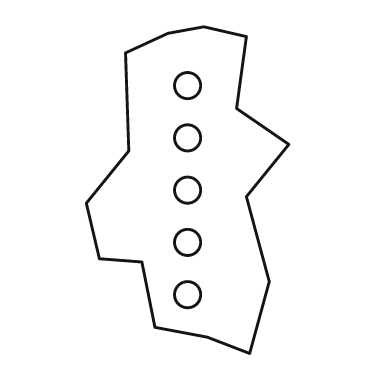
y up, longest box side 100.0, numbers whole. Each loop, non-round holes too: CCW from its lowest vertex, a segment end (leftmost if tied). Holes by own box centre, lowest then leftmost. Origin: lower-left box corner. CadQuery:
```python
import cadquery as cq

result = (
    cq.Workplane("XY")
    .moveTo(50.0, 0.0)
    .lineTo(56.0, 22.0)
    .lineTo(49.0, 48.0)
    .lineTo(62.0, 64.0)
    .lineTo(46.0, 75.0)
    .lineTo(49.0, 97.0)
    .lineTo(36.0, 100.0)
    .lineTo(25.0, 98.0)
    .lineTo(12.0, 92.0)
    .lineTo(13.0, 62.0)
    .lineTo(0.0, 46.0)
    .lineTo(4.0, 29.0)
    .lineTo(17.0, 28.0)
    .lineTo(21.0, 8.0)
    .lineTo(37.0, 5.0)
    .close()
    .moveTo(31.0, 18.0)
    .circle(4.0)
    .moveTo(31.0, 34.0)
    .circle(4.0)
    .moveTo(31.0, 50.0)
    .circle(4.0)
    .moveTo(31.0, 66.0)
    .circle(4.0)
    .moveTo(31.0, 82.0)
    .circle(4.0)
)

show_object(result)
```